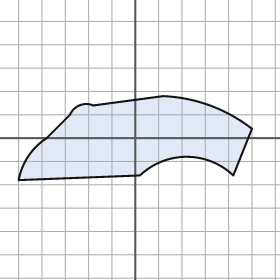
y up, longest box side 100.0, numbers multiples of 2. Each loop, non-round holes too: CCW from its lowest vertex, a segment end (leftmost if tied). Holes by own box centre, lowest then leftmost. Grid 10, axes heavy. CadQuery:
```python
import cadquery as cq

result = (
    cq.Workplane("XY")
    .moveTo(-50.0, -18.0)
    .lineTo(2.0, -16.0)
    .threePointArc((22.0, -8.0), (42.0, -16.0))
    .lineTo(50.0, 4.0)
    .threePointArc((32.0, 14.0), (12.0, 18.0))
    .lineTo(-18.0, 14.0)
    .threePointArc((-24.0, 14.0), (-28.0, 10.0))
    .lineTo(-38.0, 0.0)
    .threePointArc((-46.0, -8.0), (-50.0, -18.0))
    .close()
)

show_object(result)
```